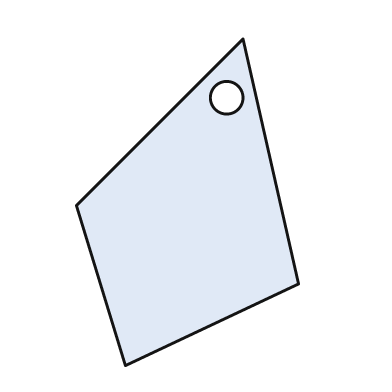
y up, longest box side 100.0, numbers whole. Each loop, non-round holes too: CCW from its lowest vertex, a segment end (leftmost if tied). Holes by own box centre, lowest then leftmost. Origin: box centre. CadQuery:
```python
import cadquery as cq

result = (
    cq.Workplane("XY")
    .moveTo(-19.0, -50.0)
    .lineTo(34.0, -25.0)
    .lineTo(17.0, 50.0)
    .lineTo(-34.0, -1.0)
    .close()
    .moveTo(12.0, 32.0)
    .circle(5.0)
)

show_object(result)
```